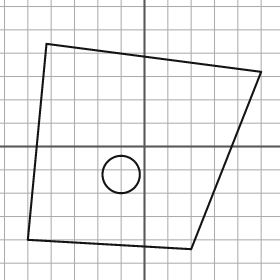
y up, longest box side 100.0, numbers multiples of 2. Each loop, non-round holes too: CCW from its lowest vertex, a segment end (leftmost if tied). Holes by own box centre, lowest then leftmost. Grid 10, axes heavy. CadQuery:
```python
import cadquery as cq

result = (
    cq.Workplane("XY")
    .moveTo(20.0, -44.0)
    .lineTo(50.0, 32.0)
    .lineTo(-42.0, 44.0)
    .lineTo(-50.0, -40.0)
    .close()
    .moveTo(-10.0, -12.0)
    .circle(8.0)
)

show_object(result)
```